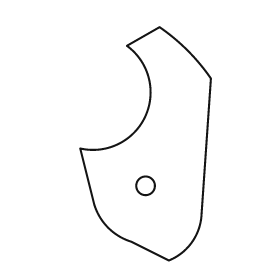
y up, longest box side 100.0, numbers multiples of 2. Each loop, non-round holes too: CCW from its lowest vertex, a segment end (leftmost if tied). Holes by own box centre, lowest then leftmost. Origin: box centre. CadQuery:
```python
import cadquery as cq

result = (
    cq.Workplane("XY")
    .moveTo(10.0, -50.0)
    .threePointArc((20.0, -42.0), (24.0, -30.0))
    .lineTo(28.0, 28.0)
    .threePointArc((18.0, 40.0), (6.0, 50.0))
    .lineTo(-8.0, 42.0)
    .threePointArc((0.0, 12.0), (-28.0, -2.0))
    .lineTo(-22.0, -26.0)
    .threePointArc((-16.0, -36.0), (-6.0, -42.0))
    .close()
    .moveTo(0.0, -18.0)
    .circle(4.0)
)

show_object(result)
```